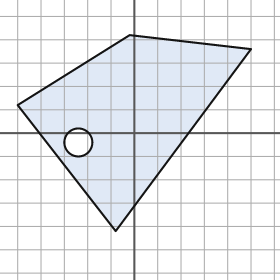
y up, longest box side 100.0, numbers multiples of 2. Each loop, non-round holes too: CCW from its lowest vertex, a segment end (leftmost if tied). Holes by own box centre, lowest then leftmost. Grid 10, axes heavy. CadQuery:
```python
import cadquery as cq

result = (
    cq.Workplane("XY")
    .moveTo(-8.0, -42.0)
    .lineTo(50.0, 36.0)
    .lineTo(-2.0, 42.0)
    .lineTo(-50.0, 12.0)
    .close()
    .moveTo(-24.0, -4.0)
    .circle(6.0)
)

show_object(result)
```